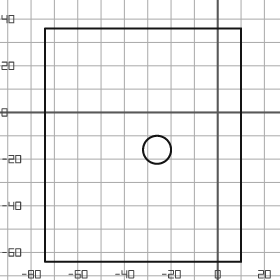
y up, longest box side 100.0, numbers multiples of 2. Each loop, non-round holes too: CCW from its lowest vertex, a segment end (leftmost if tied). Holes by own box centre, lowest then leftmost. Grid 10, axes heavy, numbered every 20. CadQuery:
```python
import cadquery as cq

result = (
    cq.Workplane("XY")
    .moveTo(-74.0, -64.0)
    .lineTo(10.0, -64.0)
    .lineTo(10.0, 36.0)
    .lineTo(-74.0, 36.0)
    .close()
    .moveTo(-26.0, -16.0)
    .circle(6.0)
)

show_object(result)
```